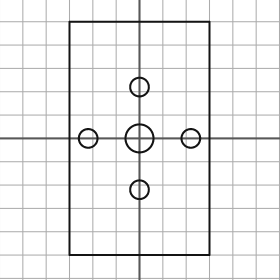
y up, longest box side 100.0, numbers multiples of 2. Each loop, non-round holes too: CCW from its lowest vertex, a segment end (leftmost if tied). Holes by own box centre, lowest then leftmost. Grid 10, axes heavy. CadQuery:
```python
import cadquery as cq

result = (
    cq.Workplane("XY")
    .moveTo(-30.0, -50.0)
    .lineTo(30.0, -50.0)
    .lineTo(30.0, 50.0)
    .lineTo(-30.0, 50.0)
    .close()
    .moveTo(0.0, -22.0)
    .circle(4.0)
    .moveTo(-22.0, 0.0)
    .circle(4.0)
    .moveTo(0.0, 0.0)
    .circle(6.0)
    .moveTo(22.0, 0.0)
    .circle(4.0)
    .moveTo(0.0, 22.0)
    .circle(4.0)
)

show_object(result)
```